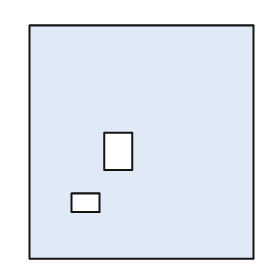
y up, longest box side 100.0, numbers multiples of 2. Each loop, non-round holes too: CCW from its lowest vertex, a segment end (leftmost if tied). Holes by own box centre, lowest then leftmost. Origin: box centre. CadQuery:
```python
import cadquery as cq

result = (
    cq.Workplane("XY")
    .moveTo(-48.0, -50.0)
    .lineTo(48.0, -50.0)
    .lineTo(48.0, 50.0)
    .lineTo(-48.0, 50.0)
    .close()
    .moveTo(-30.0, -30.0)
    .lineTo(-18.0, -30.0)
    .lineTo(-18.0, -22.0)
    .lineTo(-30.0, -22.0)
    .close()
    .moveTo(-16.0, -12.0)
    .lineTo(-4.0, -12.0)
    .lineTo(-4.0, 4.0)
    .lineTo(-16.0, 4.0)
    .close()
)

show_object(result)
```